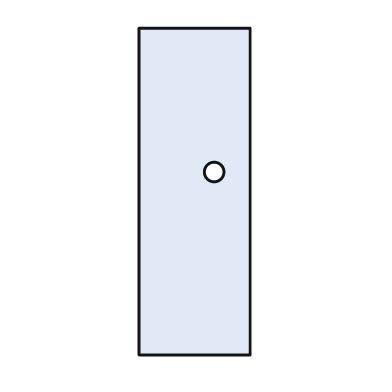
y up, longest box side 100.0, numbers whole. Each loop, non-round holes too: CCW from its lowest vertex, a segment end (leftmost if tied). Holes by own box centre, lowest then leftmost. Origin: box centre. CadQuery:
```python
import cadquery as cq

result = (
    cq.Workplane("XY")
    .moveTo(-17.0, -50.0)
    .lineTo(17.0, -50.0)
    .lineTo(17.0, 50.0)
    .lineTo(-17.0, 50.0)
    .close()
    .moveTo(6.0, 6.0)
    .circle(3.0)
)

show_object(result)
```